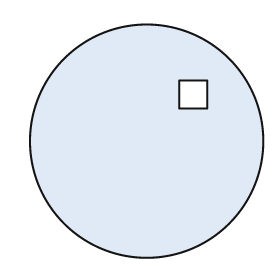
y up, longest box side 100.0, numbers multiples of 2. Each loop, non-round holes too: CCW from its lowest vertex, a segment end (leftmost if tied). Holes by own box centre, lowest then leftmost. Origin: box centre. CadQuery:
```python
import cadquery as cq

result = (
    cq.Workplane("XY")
    .moveTo(0.0, 0.0)
    .circle(50.0)
    .moveTo(14.0, 14.0)
    .lineTo(26.0, 14.0)
    .lineTo(26.0, 26.0)
    .lineTo(14.0, 26.0)
    .close()
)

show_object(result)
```